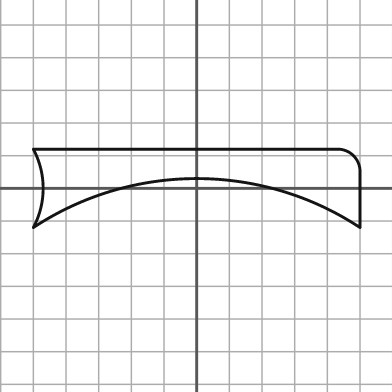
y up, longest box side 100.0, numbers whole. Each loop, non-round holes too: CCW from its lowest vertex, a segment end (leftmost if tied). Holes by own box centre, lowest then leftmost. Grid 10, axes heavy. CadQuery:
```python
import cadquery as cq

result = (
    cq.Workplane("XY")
    .moveTo(-50.0, -12.0)
    .threePointArc((0.0, 3.0), (50.0, -12.0))
    .lineTo(50.0, 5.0)
    .threePointArc((48.0, 10.0), (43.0, 12.0))
    .lineTo(-50.0, 12.0)
    .threePointArc((-47.0, 0.0), (-50.0, -12.0))
    .close()
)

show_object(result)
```